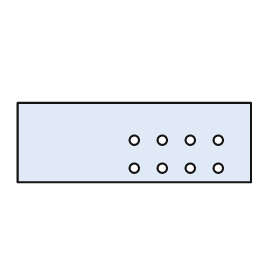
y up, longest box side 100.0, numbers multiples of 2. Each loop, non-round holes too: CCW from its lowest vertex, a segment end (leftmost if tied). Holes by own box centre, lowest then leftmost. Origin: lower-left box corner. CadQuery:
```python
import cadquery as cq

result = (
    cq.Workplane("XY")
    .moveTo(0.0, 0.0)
    .lineTo(100.0, 0.0)
    .lineTo(100.0, 34.0)
    .lineTo(0.0, 34.0)
    .close()
    .moveTo(50.0, 6.0)
    .circle(2.0)
    .moveTo(62.0, 6.0)
    .circle(2.0)
    .moveTo(74.0, 6.0)
    .circle(2.0)
    .moveTo(86.0, 6.0)
    .circle(2.0)
    .moveTo(50.0, 18.0)
    .circle(2.0)
    .moveTo(62.0, 18.0)
    .circle(2.0)
    .moveTo(74.0, 18.0)
    .circle(2.0)
    .moveTo(86.0, 18.0)
    .circle(2.0)
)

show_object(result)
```